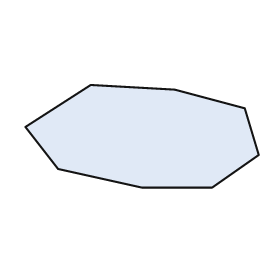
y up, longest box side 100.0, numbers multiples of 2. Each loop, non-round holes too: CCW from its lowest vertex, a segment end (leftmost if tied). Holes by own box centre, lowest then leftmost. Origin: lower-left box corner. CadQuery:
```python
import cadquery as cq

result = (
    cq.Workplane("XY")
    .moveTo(50.0, 0.0)
    .lineTo(80.0, 0.0)
    .lineTo(100.0, 14.0)
    .lineTo(94.0, 34.0)
    .lineTo(64.0, 42.0)
    .lineTo(28.0, 44.0)
    .lineTo(0.0, 26.0)
    .lineTo(14.0, 8.0)
    .close()
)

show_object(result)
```